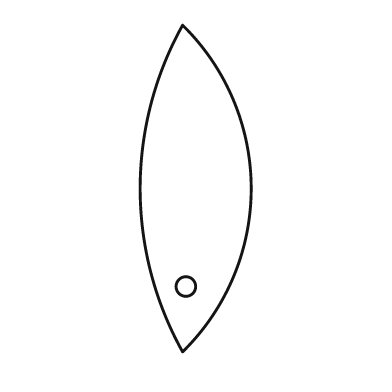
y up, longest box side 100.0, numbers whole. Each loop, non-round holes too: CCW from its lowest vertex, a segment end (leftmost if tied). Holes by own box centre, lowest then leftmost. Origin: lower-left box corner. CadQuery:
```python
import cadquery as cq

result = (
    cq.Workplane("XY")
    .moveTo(13.0, 0.0)
    .threePointArc((34.0, 50.0), (13.0, 100.0))
    .threePointArc((0.0, 50.0), (13.0, 0.0))
    .close()
    .moveTo(14.0, 20.0)
    .circle(3.0)
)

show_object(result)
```